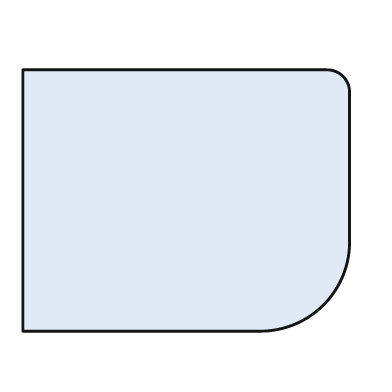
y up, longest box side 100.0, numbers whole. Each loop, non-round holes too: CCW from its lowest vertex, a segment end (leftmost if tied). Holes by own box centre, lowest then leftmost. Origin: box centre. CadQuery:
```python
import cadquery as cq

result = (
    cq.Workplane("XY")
    .moveTo(-50.0, -40.0)
    .lineTo(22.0, -40.0)
    .threePointArc((42.0, -32.0), (50.0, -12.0))
    .lineTo(50.0, 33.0)
    .threePointArc((48.0, 38.0), (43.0, 40.0))
    .lineTo(-50.0, 40.0)
    .close()
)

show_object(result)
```